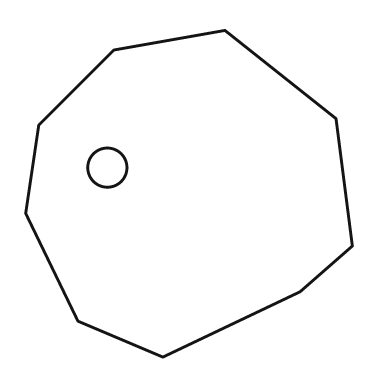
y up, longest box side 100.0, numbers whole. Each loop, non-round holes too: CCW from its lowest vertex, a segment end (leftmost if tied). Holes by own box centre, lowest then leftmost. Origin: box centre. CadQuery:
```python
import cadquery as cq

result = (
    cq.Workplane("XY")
    .moveTo(-8.0, -50.0)
    .lineTo(34.0, -30.0)
    .lineTo(50.0, -16.0)
    .lineTo(45.0, 23.0)
    .lineTo(11.0, 50.0)
    .lineTo(-23.0, 44.0)
    .lineTo(-46.0, 21.0)
    .lineTo(-50.0, -6.0)
    .lineTo(-34.0, -39.0)
    .close()
    .moveTo(-25.0, 8.0)
    .circle(6.0)
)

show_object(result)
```